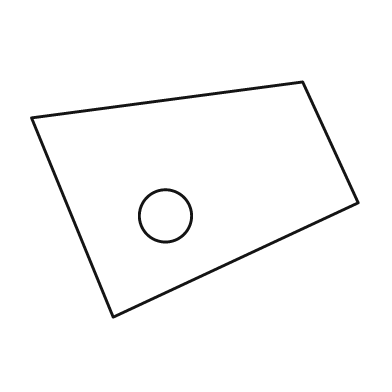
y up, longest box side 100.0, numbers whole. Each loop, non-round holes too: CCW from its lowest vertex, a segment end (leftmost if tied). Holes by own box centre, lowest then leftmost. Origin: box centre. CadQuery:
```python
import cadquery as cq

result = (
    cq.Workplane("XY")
    .moveTo(-25.0, -36.0)
    .lineTo(50.0, -1.0)
    .lineTo(33.0, 36.0)
    .lineTo(-50.0, 25.0)
    .close()
    .moveTo(-9.0, -5.0)
    .circle(8.0)
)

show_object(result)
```